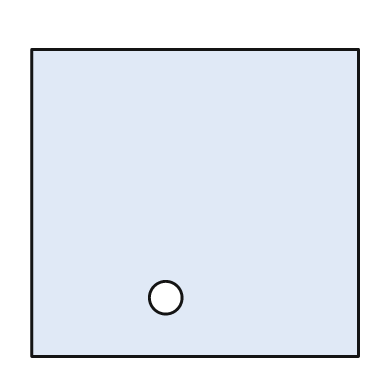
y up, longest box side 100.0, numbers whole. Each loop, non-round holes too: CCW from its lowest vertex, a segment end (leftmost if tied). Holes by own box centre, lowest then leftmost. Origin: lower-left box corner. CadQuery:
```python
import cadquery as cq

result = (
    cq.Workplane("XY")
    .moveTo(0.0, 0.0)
    .lineTo(100.0, 0.0)
    .lineTo(100.0, 94.0)
    .lineTo(0.0, 94.0)
    .close()
    .moveTo(41.0, 18.0)
    .circle(5.0)
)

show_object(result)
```